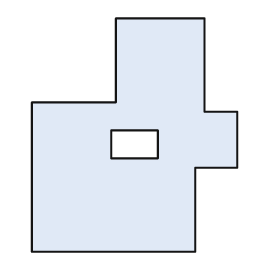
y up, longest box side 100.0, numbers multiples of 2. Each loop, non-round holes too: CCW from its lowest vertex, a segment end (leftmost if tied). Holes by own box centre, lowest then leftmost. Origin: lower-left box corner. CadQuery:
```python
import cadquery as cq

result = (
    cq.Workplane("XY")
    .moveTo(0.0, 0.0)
    .lineTo(70.0, 0.0)
    .lineTo(70.0, 36.0)
    .lineTo(88.0, 36.0)
    .lineTo(88.0, 60.0)
    .lineTo(74.0, 60.0)
    .lineTo(74.0, 100.0)
    .lineTo(36.0, 100.0)
    .lineTo(36.0, 64.0)
    .lineTo(0.0, 64.0)
    .close()
    .moveTo(34.0, 40.0)
    .lineTo(54.0, 40.0)
    .lineTo(54.0, 52.0)
    .lineTo(34.0, 52.0)
    .close()
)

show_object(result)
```